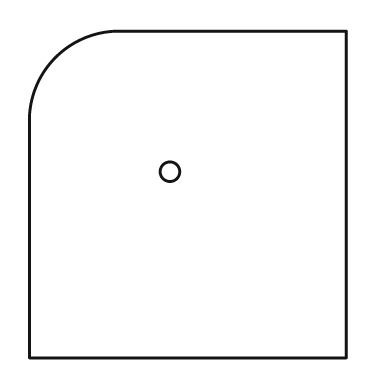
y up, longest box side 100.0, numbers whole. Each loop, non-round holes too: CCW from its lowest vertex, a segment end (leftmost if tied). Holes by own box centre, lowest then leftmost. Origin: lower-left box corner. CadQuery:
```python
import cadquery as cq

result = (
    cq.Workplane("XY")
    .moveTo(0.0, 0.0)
    .lineTo(97.0, 0.0)
    .lineTo(97.0, 100.0)
    .lineTo(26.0, 100.0)
    .threePointArc((8.0, 92.0), (0.0, 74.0))
    .close()
    .moveTo(43.0, 57.0)
    .circle(3.0)
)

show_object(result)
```